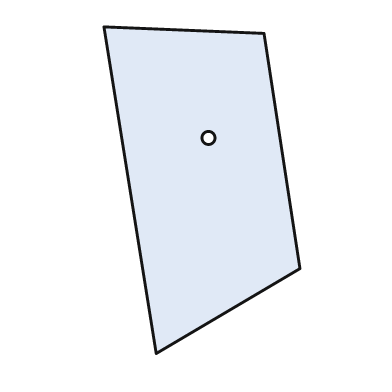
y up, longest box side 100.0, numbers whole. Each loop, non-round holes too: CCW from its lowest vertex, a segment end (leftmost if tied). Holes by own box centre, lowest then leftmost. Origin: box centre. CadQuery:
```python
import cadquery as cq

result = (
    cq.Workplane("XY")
    .moveTo(-14.0, -50.0)
    .lineTo(30.0, -24.0)
    .lineTo(19.0, 48.0)
    .lineTo(-30.0, 50.0)
    .close()
    .moveTo(2.0, 16.0)
    .circle(2.0)
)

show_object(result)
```